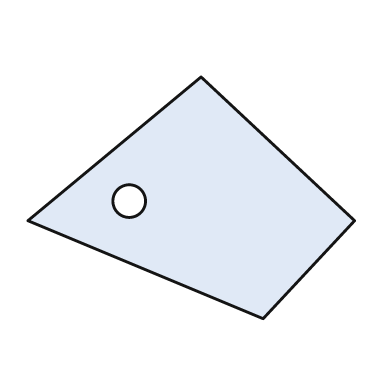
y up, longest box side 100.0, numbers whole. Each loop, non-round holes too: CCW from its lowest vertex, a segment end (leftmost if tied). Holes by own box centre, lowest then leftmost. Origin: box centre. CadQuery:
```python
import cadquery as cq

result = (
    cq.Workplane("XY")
    .moveTo(22.0, -37.0)
    .lineTo(50.0, -7.0)
    .lineTo(3.0, 37.0)
    .lineTo(-50.0, -7.0)
    .close()
    .moveTo(-19.0, -1.0)
    .circle(5.0)
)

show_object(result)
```